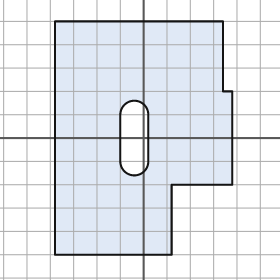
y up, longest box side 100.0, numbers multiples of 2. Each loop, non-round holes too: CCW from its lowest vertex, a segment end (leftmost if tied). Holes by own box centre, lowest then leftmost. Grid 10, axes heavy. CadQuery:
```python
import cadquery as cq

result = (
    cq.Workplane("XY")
    .moveTo(-38.0, -50.0)
    .lineTo(12.0, -50.0)
    .lineTo(12.0, -20.0)
    .lineTo(38.0, -20.0)
    .lineTo(38.0, 20.0)
    .lineTo(34.0, 20.0)
    .lineTo(34.0, 50.0)
    .lineTo(-38.0, 50.0)
    .close()
    .moveTo(-10.0, -10.0)
    .threePointArc((-4.0, -16.0), (2.0, -10.0))
    .lineTo(2.0, 10.0)
    .threePointArc((-4.0, 16.0), (-10.0, 10.0))
    .close()
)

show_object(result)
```